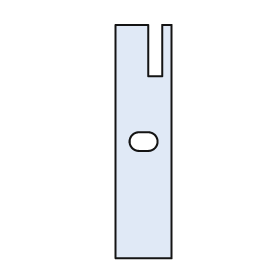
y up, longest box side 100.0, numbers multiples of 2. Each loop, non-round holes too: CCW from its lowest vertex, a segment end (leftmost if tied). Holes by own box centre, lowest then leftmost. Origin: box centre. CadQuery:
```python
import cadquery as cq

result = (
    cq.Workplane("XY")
    .moveTo(-12.0, -50.0)
    .lineTo(12.0, -50.0)
    .lineTo(12.0, 50.0)
    .lineTo(8.0, 50.0)
    .lineTo(8.0, 28.0)
    .lineTo(2.0, 28.0)
    .lineTo(2.0, 50.0)
    .lineTo(-12.0, 50.0)
    .close()
    .moveTo(-2.0, -4.0)
    .lineTo(2.0, -4.0)
    .threePointArc((6.0, 0.0), (2.0, 4.0))
    .lineTo(-2.0, 4.0)
    .threePointArc((-6.0, 0.0), (-2.0, -4.0))
    .close()
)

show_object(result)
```